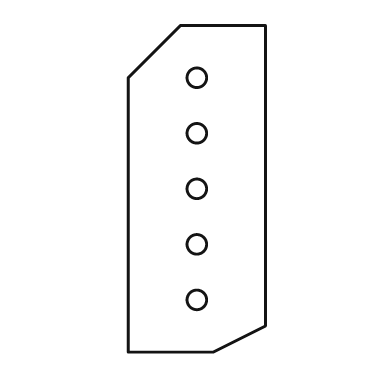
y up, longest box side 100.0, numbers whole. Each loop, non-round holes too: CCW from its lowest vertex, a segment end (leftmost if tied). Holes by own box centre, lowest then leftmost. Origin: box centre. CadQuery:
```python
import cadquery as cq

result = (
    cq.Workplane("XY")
    .moveTo(-21.0, -50.0)
    .lineTo(5.0, -50.0)
    .lineTo(21.0, -42.0)
    .lineTo(21.0, 50.0)
    .lineTo(-5.0, 50.0)
    .lineTo(-21.0, 34.0)
    .close()
    .moveTo(0.0, -34.0)
    .circle(3.0)
    .moveTo(0.0, -17.0)
    .circle(3.0)
    .moveTo(0.0, 0.0)
    .circle(3.0)
    .moveTo(0.0, 17.0)
    .circle(3.0)
    .moveTo(0.0, 34.0)
    .circle(3.0)
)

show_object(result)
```